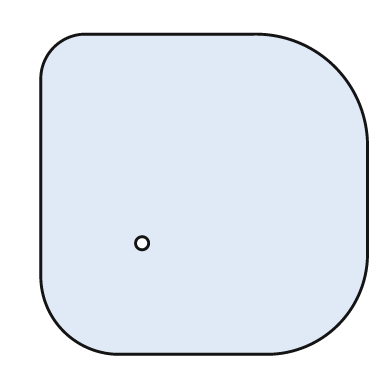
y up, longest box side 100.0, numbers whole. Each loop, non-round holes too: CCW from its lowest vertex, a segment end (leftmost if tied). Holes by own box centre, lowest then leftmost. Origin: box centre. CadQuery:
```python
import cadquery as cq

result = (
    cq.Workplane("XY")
    .moveTo(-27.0, -49.0)
    .lineTo(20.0, -49.0)
    .threePointArc((41.0, -40.0), (50.0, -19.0))
    .lineTo(50.0, 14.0)
    .threePointArc((40.0, 39.0), (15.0, 49.0))
    .lineTo(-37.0, 49.0)
    .threePointArc((-46.0, 45.0), (-50.0, 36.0))
    .lineTo(-50.0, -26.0)
    .threePointArc((-43.0, -42.0), (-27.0, -49.0))
    .close()
    .moveTo(-19.0, -15.0)
    .circle(2.0)
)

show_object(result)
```